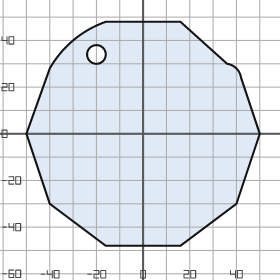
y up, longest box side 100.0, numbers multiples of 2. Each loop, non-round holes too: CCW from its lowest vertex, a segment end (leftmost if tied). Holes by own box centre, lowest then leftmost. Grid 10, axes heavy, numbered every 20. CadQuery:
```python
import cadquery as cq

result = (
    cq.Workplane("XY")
    .moveTo(-16.0, -48.0)
    .lineTo(16.0, -48.0)
    .lineTo(40.0, -30.0)
    .lineTo(50.0, 0.0)
    .lineTo(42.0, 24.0)
    .threePointArc((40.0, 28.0), (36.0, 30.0))
    .lineTo(16.0, 48.0)
    .lineTo(-16.0, 48.0)
    .threePointArc((-30.0, 40.0), (-40.0, 28.0))
    .lineTo(-50.0, 0.0)
    .lineTo(-40.0, -30.0)
    .close()
    .moveTo(-20.0, 34.0)
    .circle(4.0)
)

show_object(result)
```